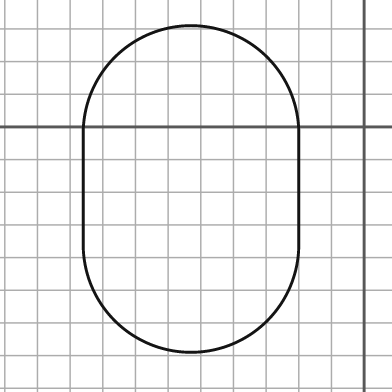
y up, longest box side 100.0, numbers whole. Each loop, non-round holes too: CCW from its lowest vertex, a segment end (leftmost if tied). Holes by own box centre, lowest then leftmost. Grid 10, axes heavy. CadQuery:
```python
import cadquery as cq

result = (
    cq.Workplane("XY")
    .moveTo(-86.0, -36.0)
    .threePointArc((-53.0, -69.0), (-20.0, -36.0))
    .lineTo(-20.0, -2.0)
    .threePointArc((-53.0, 31.0), (-86.0, -2.0))
    .close()
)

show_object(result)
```